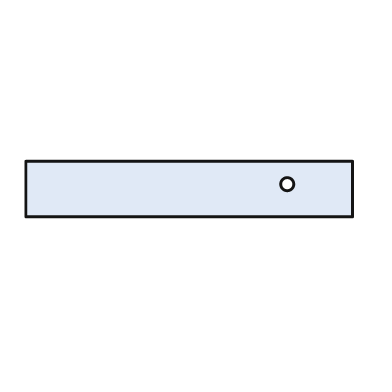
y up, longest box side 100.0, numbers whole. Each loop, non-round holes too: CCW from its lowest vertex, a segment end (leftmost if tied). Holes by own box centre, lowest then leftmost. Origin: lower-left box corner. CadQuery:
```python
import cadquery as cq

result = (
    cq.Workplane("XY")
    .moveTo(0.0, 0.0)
    .lineTo(100.0, 0.0)
    .lineTo(100.0, 17.0)
    .lineTo(0.0, 17.0)
    .close()
    .moveTo(80.0, 10.0)
    .circle(2.0)
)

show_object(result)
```